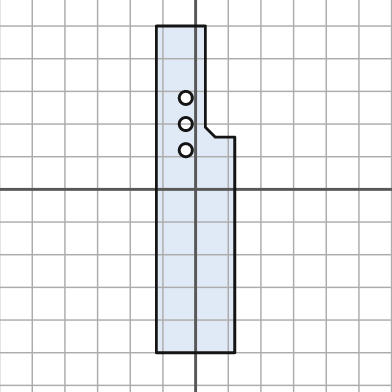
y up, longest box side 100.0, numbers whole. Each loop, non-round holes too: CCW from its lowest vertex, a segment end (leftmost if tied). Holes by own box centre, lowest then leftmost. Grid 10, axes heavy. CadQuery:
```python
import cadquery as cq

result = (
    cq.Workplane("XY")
    .moveTo(-12.0, -50.0)
    .lineTo(12.0, -50.0)
    .lineTo(12.0, 16.0)
    .lineTo(6.0, 16.0)
    .lineTo(3.0, 19.0)
    .lineTo(3.0, 50.0)
    .lineTo(-12.0, 50.0)
    .close()
    .moveTo(-3.0, 12.0)
    .circle(2.0)
    .moveTo(-3.0, 20.0)
    .circle(2.0)
    .moveTo(-3.0, 28.0)
    .circle(2.0)
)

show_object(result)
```